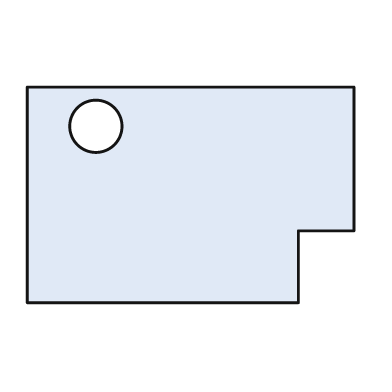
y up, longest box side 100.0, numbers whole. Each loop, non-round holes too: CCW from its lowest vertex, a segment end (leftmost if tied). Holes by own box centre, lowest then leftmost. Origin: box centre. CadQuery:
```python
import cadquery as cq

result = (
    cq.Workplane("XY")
    .moveTo(-50.0, -33.0)
    .lineTo(33.0, -33.0)
    .lineTo(33.0, -11.0)
    .lineTo(50.0, -11.0)
    .lineTo(50.0, 33.0)
    .lineTo(-50.0, 33.0)
    .close()
    .moveTo(-29.0, 21.0)
    .circle(8.0)
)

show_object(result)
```